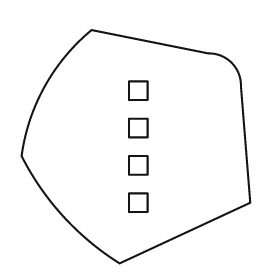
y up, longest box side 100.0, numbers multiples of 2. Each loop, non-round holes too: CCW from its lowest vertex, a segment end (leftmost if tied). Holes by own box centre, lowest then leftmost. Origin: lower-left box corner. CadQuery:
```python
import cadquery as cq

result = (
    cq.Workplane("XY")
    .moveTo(42.0, 0.0)
    .lineTo(98.0, 26.0)
    .lineTo(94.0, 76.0)
    .threePointArc((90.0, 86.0), (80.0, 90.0))
    .lineTo(30.0, 100.0)
    .threePointArc((10.0, 76.0), (0.0, 46.0))
    .threePointArc((18.0, 20.0), (42.0, 0.0))
    .close()
    .moveTo(46.0, 22.0)
    .lineTo(54.0, 22.0)
    .lineTo(54.0, 30.0)
    .lineTo(46.0, 30.0)
    .close()
    .moveTo(46.0, 38.0)
    .lineTo(54.0, 38.0)
    .lineTo(54.0, 46.0)
    .lineTo(46.0, 46.0)
    .close()
    .moveTo(46.0, 54.0)
    .lineTo(54.0, 54.0)
    .lineTo(54.0, 62.0)
    .lineTo(46.0, 62.0)
    .close()
    .moveTo(46.0, 70.0)
    .lineTo(54.0, 70.0)
    .lineTo(54.0, 78.0)
    .lineTo(46.0, 78.0)
    .close()
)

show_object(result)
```